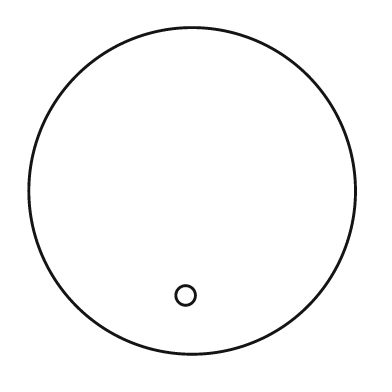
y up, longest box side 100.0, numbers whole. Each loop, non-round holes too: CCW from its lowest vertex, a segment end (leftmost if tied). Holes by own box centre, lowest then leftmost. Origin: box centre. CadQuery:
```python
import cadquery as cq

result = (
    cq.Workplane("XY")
    .moveTo(0.0, 0.0)
    .circle(50.0)
    .moveTo(-2.0, -32.0)
    .circle(3.0)
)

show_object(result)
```